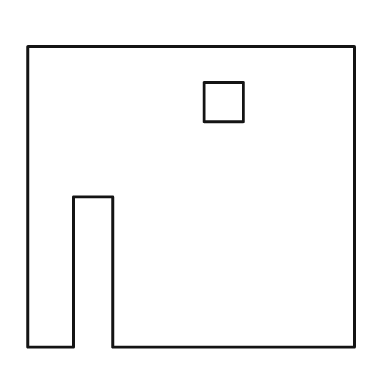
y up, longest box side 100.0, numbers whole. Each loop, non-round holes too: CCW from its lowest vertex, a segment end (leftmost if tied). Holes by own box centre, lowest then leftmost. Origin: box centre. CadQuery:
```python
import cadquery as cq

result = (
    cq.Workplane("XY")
    .moveTo(-50.0, -46.0)
    .lineTo(-36.0, -46.0)
    .lineTo(-36.0, 0.0)
    .lineTo(-24.0, 0.0)
    .lineTo(-24.0, -46.0)
    .lineTo(50.0, -46.0)
    .lineTo(50.0, 46.0)
    .lineTo(-50.0, 46.0)
    .close()
    .moveTo(4.0, 23.0)
    .lineTo(16.0, 23.0)
    .lineTo(16.0, 35.0)
    .lineTo(4.0, 35.0)
    .close()
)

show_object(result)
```